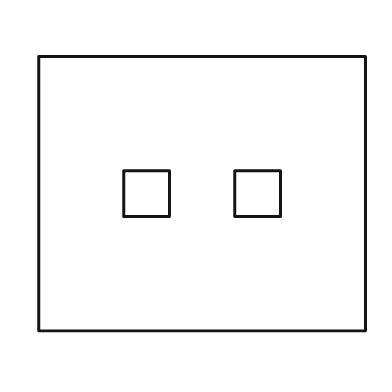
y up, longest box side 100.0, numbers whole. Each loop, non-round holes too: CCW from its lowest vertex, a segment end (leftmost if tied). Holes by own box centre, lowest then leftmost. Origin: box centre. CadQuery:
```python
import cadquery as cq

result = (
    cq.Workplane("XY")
    .moveTo(-50.0, -42.0)
    .lineTo(50.0, -42.0)
    .lineTo(50.0, 42.0)
    .lineTo(-50.0, 42.0)
    .close()
    .moveTo(-24.0, -7.0)
    .lineTo(-10.0, -7.0)
    .lineTo(-10.0, 7.0)
    .lineTo(-24.0, 7.0)
    .close()
    .moveTo(10.0, -7.0)
    .lineTo(24.0, -7.0)
    .lineTo(24.0, 7.0)
    .lineTo(10.0, 7.0)
    .close()
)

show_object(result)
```